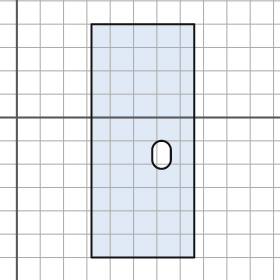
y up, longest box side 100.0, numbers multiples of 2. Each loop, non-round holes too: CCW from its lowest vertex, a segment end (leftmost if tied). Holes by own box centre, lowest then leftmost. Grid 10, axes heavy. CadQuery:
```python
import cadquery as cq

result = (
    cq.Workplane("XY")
    .moveTo(32.0, -60.0)
    .lineTo(76.0, -60.0)
    .lineTo(76.0, 40.0)
    .lineTo(32.0, 40.0)
    .close()
    .moveTo(58.0, -18.0)
    .threePointArc((62.0, -22.0), (66.0, -18.0))
    .lineTo(66.0, -14.0)
    .threePointArc((62.0, -10.0), (58.0, -14.0))
    .close()
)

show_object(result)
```